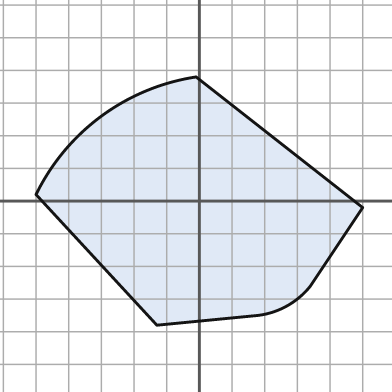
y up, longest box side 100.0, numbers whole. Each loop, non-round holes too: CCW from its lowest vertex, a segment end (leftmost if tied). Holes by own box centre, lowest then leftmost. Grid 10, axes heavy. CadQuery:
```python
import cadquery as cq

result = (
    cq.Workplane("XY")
    .moveTo(-13.0, -38.0)
    .lineTo(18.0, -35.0)
    .threePointArc((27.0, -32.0), (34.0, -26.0))
    .lineTo(50.0, -2.0)
    .lineTo(-1.0, 38.0)
    .threePointArc((-30.0, 26.0), (-50.0, 2.0))
    .close()
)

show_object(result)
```